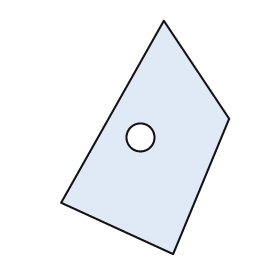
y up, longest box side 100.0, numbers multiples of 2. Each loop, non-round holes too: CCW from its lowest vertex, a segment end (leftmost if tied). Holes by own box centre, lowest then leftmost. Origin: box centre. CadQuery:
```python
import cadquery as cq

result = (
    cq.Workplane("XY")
    .moveTo(12.0, -50.0)
    .lineTo(36.0, 8.0)
    .lineTo(8.0, 50.0)
    .lineTo(-36.0, -28.0)
    .close()
    .moveTo(-2.0, 0.0)
    .circle(6.0)
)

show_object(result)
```